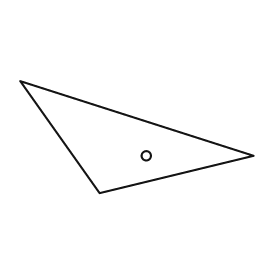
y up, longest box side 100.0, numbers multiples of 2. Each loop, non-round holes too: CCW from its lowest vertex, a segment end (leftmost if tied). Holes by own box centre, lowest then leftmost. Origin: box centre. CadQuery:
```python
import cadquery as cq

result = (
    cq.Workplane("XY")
    .moveTo(-16.0, -24.0)
    .lineTo(50.0, -8.0)
    .lineTo(-50.0, 24.0)
    .close()
    .moveTo(4.0, -8.0)
    .circle(2.0)
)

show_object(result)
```